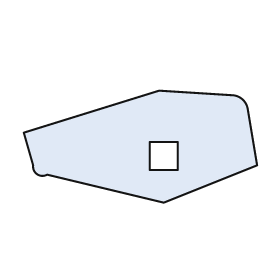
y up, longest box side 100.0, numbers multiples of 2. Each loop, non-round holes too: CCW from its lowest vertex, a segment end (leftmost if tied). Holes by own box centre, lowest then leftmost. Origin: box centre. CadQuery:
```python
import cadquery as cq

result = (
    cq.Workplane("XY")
    .moveTo(10.0, -24.0)
    .lineTo(50.0, -8.0)
    .lineTo(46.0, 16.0)
    .threePointArc((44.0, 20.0), (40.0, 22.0))
    .lineTo(8.0, 24.0)
    .lineTo(-50.0, 6.0)
    .lineTo(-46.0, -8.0)
    .threePointArc((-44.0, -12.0), (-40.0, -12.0))
    .close()
    .moveTo(4.0, -10.0)
    .lineTo(16.0, -10.0)
    .lineTo(16.0, 2.0)
    .lineTo(4.0, 2.0)
    .close()
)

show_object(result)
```